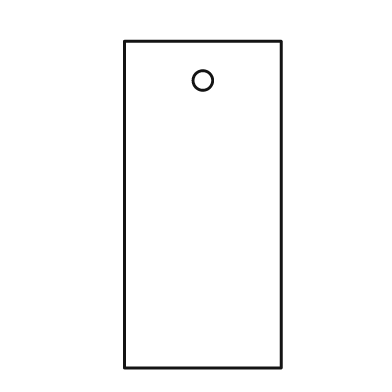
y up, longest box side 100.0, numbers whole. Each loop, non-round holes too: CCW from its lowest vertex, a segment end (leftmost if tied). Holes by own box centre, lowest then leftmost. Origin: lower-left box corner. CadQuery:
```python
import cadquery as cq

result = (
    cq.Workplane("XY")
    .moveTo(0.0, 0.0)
    .lineTo(48.0, 0.0)
    .lineTo(48.0, 100.0)
    .lineTo(0.0, 100.0)
    .close()
    .moveTo(24.0, 88.0)
    .circle(3.0)
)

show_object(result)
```